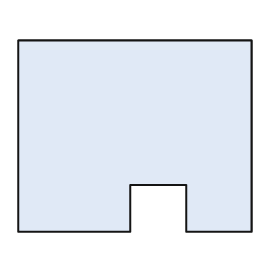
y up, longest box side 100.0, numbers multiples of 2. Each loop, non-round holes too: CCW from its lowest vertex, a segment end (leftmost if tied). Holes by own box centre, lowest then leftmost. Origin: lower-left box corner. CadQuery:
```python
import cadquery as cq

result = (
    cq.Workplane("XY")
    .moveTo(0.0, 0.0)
    .lineTo(48.0, 0.0)
    .lineTo(48.0, 20.0)
    .lineTo(72.0, 20.0)
    .lineTo(72.0, 0.0)
    .lineTo(100.0, 0.0)
    .lineTo(100.0, 82.0)
    .lineTo(0.0, 82.0)
    .close()
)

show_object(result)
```